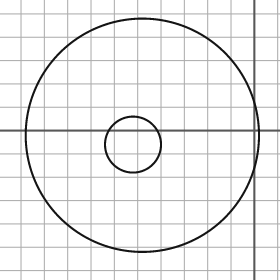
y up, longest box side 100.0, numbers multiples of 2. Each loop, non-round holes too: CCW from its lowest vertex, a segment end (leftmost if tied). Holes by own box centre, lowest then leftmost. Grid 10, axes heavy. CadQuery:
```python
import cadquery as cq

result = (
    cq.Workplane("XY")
    .moveTo(-48.0, -2.0)
    .circle(50.0)
    .moveTo(-52.0, -6.0)
    .circle(12.0)
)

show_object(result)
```